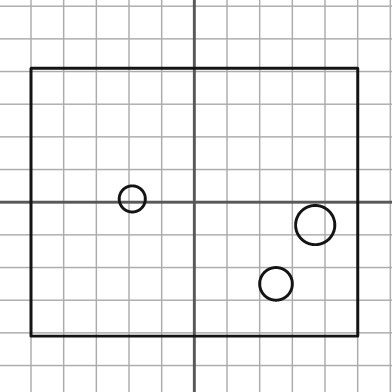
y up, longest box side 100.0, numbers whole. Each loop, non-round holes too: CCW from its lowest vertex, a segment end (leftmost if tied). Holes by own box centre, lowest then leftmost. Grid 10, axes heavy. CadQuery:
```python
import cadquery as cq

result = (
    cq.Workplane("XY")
    .moveTo(-50.0, -41.0)
    .lineTo(50.0, -41.0)
    .lineTo(50.0, 41.0)
    .lineTo(-50.0, 41.0)
    .close()
    .moveTo(25.0, -25.0)
    .circle(5.0)
    .moveTo(37.0, -7.0)
    .circle(6.0)
    .moveTo(-19.0, 1.0)
    .circle(4.0)
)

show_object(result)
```